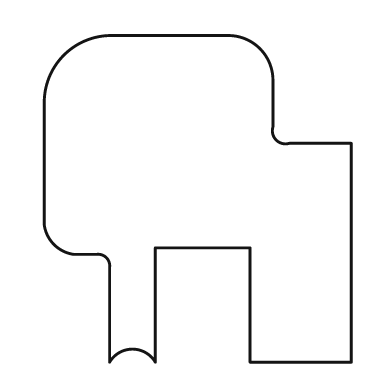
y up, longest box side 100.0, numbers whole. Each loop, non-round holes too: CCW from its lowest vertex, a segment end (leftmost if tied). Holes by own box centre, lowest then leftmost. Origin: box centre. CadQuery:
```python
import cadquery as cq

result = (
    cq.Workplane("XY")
    .moveTo(-27.0, -50.0)
    .threePointArc((-20.0, -46.0), (-13.0, -50.0))
    .lineTo(-13.0, -15.0)
    .lineTo(16.0, -15.0)
    .lineTo(16.0, -50.0)
    .lineTo(47.0, -50.0)
    .lineTo(47.0, 17.0)
    .lineTo(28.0, 17.0)
    .threePointArc((24.0, 18.0), (23.0, 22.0))
    .lineTo(23.0, 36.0)
    .threePointArc((19.0, 46.0), (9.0, 50.0))
    .lineTo(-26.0, 50.0)
    .threePointArc((-41.0, 44.0), (-47.0, 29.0))
    .lineTo(-47.0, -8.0)
    .threePointArc((-44.0, -14.0), (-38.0, -17.0))
    .lineTo(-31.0, -17.0)
    .threePointArc((-28.0, -18.0), (-27.0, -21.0))
    .close()
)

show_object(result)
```